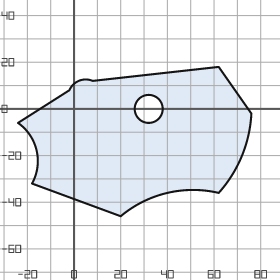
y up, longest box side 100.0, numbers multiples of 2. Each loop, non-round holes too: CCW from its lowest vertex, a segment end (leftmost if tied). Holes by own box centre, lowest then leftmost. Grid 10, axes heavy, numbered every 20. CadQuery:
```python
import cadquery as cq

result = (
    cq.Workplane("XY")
    .moveTo(20.0, -46.0)
    .threePointArc((40.0, -36.0), (62.0, -36.0))
    .threePointArc((72.0, -20.0), (76.0, -2.0))
    .lineTo(62.0, 18.0)
    .lineTo(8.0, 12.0)
    .threePointArc((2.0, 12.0), (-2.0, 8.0))
    .lineTo(-24.0, -6.0)
    .threePointArc((-16.0, -18.0), (-18.0, -32.0))
    .close()
    .moveTo(32.0, 0.0)
    .circle(6.0)
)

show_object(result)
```